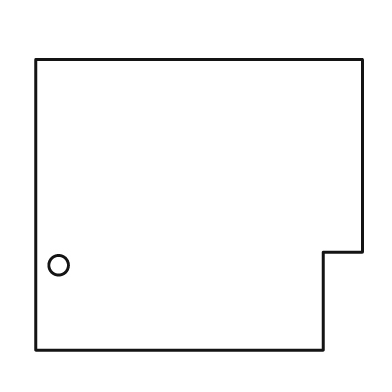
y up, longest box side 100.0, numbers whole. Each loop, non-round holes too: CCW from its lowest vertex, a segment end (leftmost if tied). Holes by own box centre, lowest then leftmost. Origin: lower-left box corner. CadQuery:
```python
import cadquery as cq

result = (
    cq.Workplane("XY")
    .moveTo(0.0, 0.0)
    .lineTo(88.0, 0.0)
    .lineTo(88.0, 30.0)
    .lineTo(100.0, 30.0)
    .lineTo(100.0, 89.0)
    .lineTo(0.0, 89.0)
    .close()
    .moveTo(7.0, 26.0)
    .circle(3.0)
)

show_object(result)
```